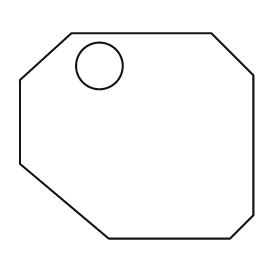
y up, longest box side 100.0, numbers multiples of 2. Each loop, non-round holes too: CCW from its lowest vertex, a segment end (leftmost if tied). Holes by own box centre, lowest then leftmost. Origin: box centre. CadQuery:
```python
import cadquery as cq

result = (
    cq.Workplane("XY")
    .moveTo(-12.0, -44.0)
    .lineTo(40.0, -44.0)
    .lineTo(50.0, -34.0)
    .lineTo(50.0, 26.0)
    .lineTo(32.0, 44.0)
    .lineTo(-28.0, 44.0)
    .lineTo(-50.0, 24.0)
    .lineTo(-50.0, -12.0)
    .close()
    .moveTo(-16.0, 30.0)
    .circle(10.0)
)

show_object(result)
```